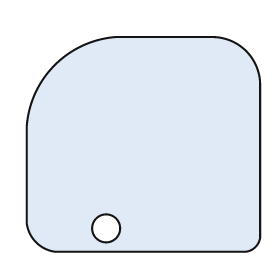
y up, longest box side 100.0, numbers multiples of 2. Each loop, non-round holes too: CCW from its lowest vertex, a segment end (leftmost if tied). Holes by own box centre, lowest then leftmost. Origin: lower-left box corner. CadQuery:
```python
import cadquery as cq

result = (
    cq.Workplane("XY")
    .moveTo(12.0, 0.0)
    .lineTo(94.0, 0.0)
    .threePointArc((98.0, 2.0), (100.0, 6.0))
    .lineTo(100.0, 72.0)
    .threePointArc((94.0, 86.0), (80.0, 92.0))
    .lineTo(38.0, 92.0)
    .threePointArc((12.0, 80.0), (0.0, 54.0))
    .lineTo(0.0, 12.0)
    .threePointArc((4.0, 4.0), (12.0, 0.0))
    .close()
    .moveTo(34.0, 10.0)
    .circle(6.0)
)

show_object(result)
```